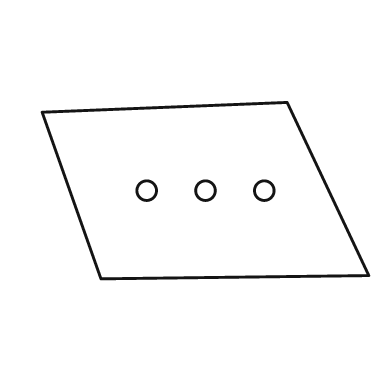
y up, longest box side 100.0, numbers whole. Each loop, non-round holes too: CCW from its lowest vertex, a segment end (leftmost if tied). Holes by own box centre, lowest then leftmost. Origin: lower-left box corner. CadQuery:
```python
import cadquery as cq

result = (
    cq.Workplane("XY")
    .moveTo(18.0, 0.0)
    .lineTo(100.0, 1.0)
    .lineTo(75.0, 54.0)
    .lineTo(0.0, 51.0)
    .close()
    .moveTo(32.0, 27.0)
    .circle(3.0)
    .moveTo(50.0, 27.0)
    .circle(3.0)
    .moveTo(68.0, 27.0)
    .circle(3.0)
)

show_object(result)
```